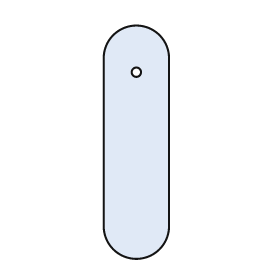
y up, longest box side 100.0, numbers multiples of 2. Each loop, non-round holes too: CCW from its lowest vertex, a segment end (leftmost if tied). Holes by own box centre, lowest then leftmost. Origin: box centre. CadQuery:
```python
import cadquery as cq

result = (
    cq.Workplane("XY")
    .moveTo(-14.0, -36.0)
    .threePointArc((0.0, -50.0), (14.0, -36.0))
    .lineTo(14.0, 36.0)
    .threePointArc((0.0, 50.0), (-14.0, 36.0))
    .close()
    .moveTo(0.0, 30.0)
    .circle(2.0)
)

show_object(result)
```